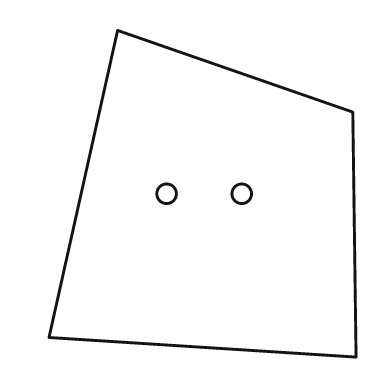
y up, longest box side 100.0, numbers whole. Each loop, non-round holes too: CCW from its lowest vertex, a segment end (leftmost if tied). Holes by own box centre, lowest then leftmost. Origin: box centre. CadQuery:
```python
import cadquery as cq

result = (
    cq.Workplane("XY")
    .moveTo(47.0, -50.0)
    .lineTo(46.0, 25.0)
    .lineTo(-26.0, 50.0)
    .lineTo(-47.0, -44.0)
    .close()
    .moveTo(-11.0, 0.0)
    .circle(3.0)
    .moveTo(12.0, 0.0)
    .circle(3.0)
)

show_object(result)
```